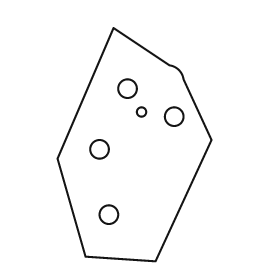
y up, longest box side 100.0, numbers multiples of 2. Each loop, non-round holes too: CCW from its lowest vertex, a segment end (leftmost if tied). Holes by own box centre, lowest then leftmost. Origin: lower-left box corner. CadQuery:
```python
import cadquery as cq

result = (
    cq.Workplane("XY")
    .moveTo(42.0, 0.0)
    .lineTo(66.0, 52.0)
    .lineTo(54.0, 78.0)
    .threePointArc((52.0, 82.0), (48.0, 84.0))
    .lineTo(24.0, 100.0)
    .lineTo(0.0, 44.0)
    .lineTo(12.0, 2.0)
    .close()
    .moveTo(22.0, 20.0)
    .circle(4.0)
    .moveTo(18.0, 48.0)
    .circle(4.0)
    .moveTo(50.0, 62.0)
    .circle(4.0)
    .moveTo(36.0, 64.0)
    .circle(2.0)
    .moveTo(30.0, 74.0)
    .circle(4.0)
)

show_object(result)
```